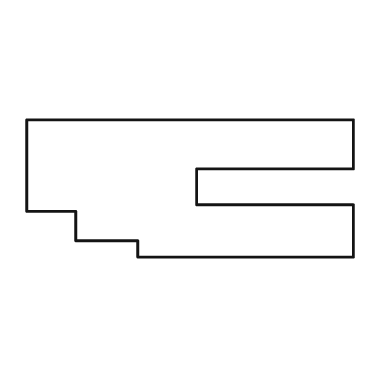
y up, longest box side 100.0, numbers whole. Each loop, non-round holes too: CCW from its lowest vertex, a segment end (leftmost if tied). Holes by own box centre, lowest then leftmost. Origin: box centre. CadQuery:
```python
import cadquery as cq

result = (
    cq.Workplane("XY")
    .moveTo(-16.0, -21.0)
    .lineTo(50.0, -21.0)
    .lineTo(50.0, -5.0)
    .lineTo(2.0, -5.0)
    .lineTo(2.0, 6.0)
    .lineTo(50.0, 6.0)
    .lineTo(50.0, 21.0)
    .lineTo(-50.0, 21.0)
    .lineTo(-50.0, -7.0)
    .lineTo(-35.0, -7.0)
    .lineTo(-35.0, -16.0)
    .lineTo(-16.0, -16.0)
    .close()
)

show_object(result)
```